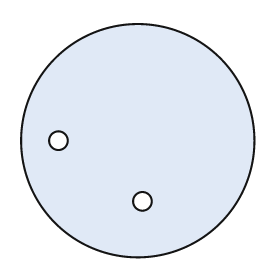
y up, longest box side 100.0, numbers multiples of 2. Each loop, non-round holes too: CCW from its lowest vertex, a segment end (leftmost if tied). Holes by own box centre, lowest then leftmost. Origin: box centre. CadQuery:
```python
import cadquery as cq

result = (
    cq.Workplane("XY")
    .moveTo(0.0, 0.0)
    .circle(50.0)
    .moveTo(2.0, -26.0)
    .circle(4.0)
    .moveTo(-34.0, 0.0)
    .circle(4.0)
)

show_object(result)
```